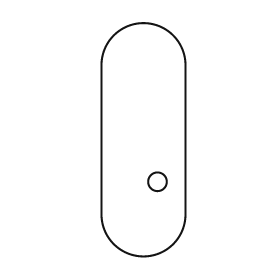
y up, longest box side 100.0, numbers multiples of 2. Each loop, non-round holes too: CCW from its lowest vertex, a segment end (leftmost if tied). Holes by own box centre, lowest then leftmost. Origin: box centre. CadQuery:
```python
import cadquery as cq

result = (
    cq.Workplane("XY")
    .moveTo(-18.0, -32.0)
    .threePointArc((0.0, -50.0), (18.0, -32.0))
    .lineTo(18.0, 32.0)
    .threePointArc((0.0, 50.0), (-18.0, 32.0))
    .close()
    .moveTo(6.0, -18.0)
    .circle(4.0)
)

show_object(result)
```